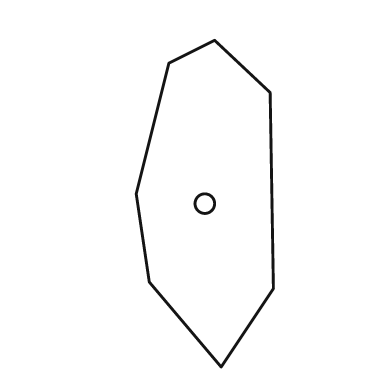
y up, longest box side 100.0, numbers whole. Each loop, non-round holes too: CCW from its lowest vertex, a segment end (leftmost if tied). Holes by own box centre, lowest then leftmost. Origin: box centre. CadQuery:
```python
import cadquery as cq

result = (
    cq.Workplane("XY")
    .moveTo(5.0, -50.0)
    .lineTo(21.0, -26.0)
    .lineTo(20.0, 34.0)
    .lineTo(3.0, 50.0)
    .lineTo(-11.0, 43.0)
    .lineTo(-21.0, 3.0)
    .lineTo(-17.0, -24.0)
    .close()
    .moveTo(0.0, 0.0)
    .circle(3.0)
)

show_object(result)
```